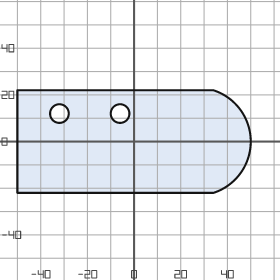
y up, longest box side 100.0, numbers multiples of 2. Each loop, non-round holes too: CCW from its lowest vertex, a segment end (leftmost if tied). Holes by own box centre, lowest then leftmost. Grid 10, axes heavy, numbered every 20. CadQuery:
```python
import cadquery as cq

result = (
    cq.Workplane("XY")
    .moveTo(-50.0, -22.0)
    .lineTo(34.0, -22.0)
    .threePointArc((50.0, 0.0), (34.0, 22.0))
    .lineTo(-50.0, 22.0)
    .close()
    .moveTo(-32.0, 12.0)
    .circle(4.0)
    .moveTo(-6.0, 12.0)
    .circle(4.0)
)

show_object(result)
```